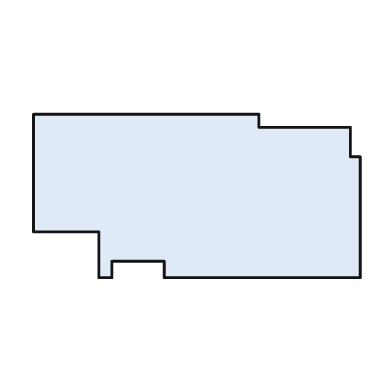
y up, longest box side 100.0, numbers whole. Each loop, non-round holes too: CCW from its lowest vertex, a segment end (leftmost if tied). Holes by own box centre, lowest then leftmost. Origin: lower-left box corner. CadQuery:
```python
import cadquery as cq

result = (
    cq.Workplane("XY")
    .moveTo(20.0, 0.0)
    .lineTo(24.0, 0.0)
    .lineTo(24.0, 5.0)
    .lineTo(40.0, 5.0)
    .lineTo(40.0, 0.0)
    .lineTo(100.0, 0.0)
    .lineTo(100.0, 37.0)
    .lineTo(97.0, 37.0)
    .lineTo(97.0, 46.0)
    .lineTo(69.0, 46.0)
    .lineTo(69.0, 50.0)
    .lineTo(0.0, 50.0)
    .lineTo(0.0, 14.0)
    .lineTo(20.0, 14.0)
    .close()
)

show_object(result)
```